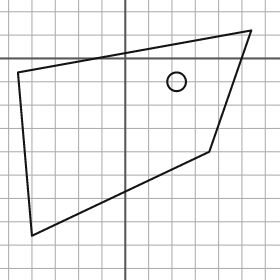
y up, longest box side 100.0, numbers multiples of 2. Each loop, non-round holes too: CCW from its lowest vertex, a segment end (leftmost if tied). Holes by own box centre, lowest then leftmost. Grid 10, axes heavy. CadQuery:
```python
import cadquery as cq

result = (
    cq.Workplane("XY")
    .moveTo(-40.0, -76.0)
    .lineTo(36.0, -40.0)
    .lineTo(54.0, 12.0)
    .lineTo(-46.0, -6.0)
    .close()
    .moveTo(22.0, -10.0)
    .circle(4.0)
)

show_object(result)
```